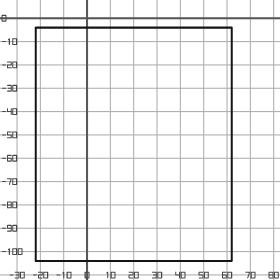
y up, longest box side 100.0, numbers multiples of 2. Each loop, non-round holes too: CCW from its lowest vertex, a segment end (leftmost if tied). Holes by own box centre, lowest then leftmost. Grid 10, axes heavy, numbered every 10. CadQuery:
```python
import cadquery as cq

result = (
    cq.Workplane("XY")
    .moveTo(-22.0, -104.0)
    .lineTo(62.0, -104.0)
    .lineTo(62.0, -4.0)
    .lineTo(-22.0, -4.0)
    .close()
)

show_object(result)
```